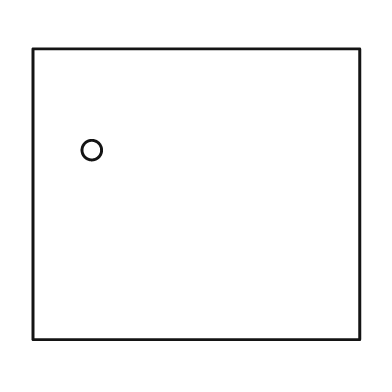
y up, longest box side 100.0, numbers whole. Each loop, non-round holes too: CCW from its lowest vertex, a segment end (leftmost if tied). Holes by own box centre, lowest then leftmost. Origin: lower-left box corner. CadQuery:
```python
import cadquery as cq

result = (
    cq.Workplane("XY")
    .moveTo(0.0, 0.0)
    .lineTo(100.0, 0.0)
    .lineTo(100.0, 89.0)
    .lineTo(0.0, 89.0)
    .close()
    .moveTo(18.0, 58.0)
    .circle(3.0)
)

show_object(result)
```